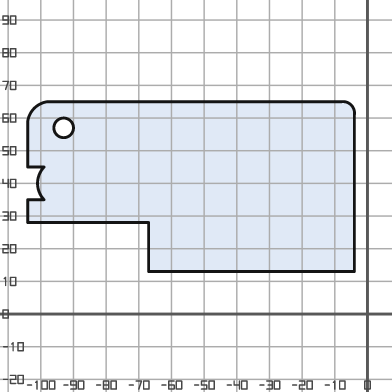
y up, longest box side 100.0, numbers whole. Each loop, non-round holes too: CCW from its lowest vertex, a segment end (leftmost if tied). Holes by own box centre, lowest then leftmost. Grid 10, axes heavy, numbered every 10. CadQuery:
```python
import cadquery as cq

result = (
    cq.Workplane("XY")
    .moveTo(-67.0, 13.0)
    .lineTo(-4.0, 13.0)
    .lineTo(-4.0, 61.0)
    .threePointArc((-5.0, 64.0), (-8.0, 65.0))
    .lineTo(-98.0, 65.0)
    .threePointArc((-102.0, 63.0), (-104.0, 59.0))
    .lineTo(-104.0, 45.0)
    .lineTo(-99.0, 45.0)
    .threePointArc((-101.0, 40.0), (-99.0, 35.0))
    .lineTo(-104.0, 35.0)
    .lineTo(-104.0, 28.0)
    .lineTo(-67.0, 28.0)
    .close()
    .moveTo(-93.0, 57.0)
    .circle(3.0)
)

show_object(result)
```